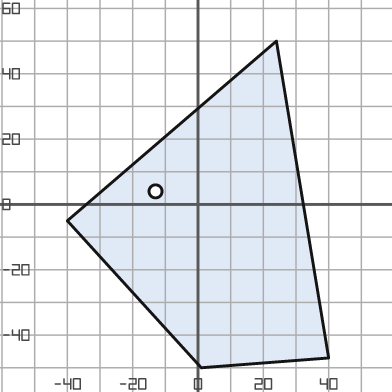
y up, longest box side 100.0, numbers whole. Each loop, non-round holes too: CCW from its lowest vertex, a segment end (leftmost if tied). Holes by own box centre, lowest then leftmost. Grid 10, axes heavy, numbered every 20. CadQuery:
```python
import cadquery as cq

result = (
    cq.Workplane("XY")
    .moveTo(1.0, -50.0)
    .lineTo(40.0, -47.0)
    .lineTo(24.0, 50.0)
    .lineTo(-40.0, -5.0)
    .close()
    .moveTo(-13.0, 4.0)
    .circle(2.0)
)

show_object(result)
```